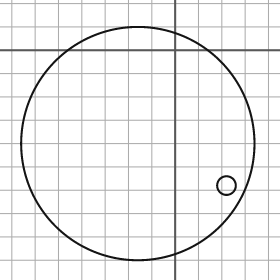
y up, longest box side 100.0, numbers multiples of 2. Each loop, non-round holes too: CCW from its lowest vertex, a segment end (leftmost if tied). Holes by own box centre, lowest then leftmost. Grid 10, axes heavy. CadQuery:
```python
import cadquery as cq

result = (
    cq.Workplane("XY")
    .moveTo(-16.0, -40.0)
    .circle(50.0)
    .moveTo(22.0, -58.0)
    .circle(4.0)
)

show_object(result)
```